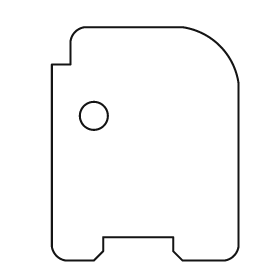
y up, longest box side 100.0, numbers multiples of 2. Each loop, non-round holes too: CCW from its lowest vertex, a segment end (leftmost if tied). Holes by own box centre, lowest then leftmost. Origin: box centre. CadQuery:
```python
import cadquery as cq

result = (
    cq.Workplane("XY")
    .moveTo(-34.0, -50.0)
    .lineTo(-22.0, -50.0)
    .lineTo(-18.0, -46.0)
    .lineTo(-18.0, -40.0)
    .lineTo(12.0, -40.0)
    .lineTo(12.0, -46.0)
    .lineTo(16.0, -50.0)
    .lineTo(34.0, -50.0)
    .threePointArc((38.0, -48.0), (40.0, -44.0))
    .lineTo(40.0, 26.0)
    .threePointArc((32.0, 42.0), (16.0, 50.0))
    .lineTo(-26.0, 50.0)
    .threePointArc((-30.0, 48.0), (-32.0, 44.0))
    .lineTo(-32.0, 34.0)
    .lineTo(-40.0, 34.0)
    .lineTo(-40.0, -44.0)
    .threePointArc((-38.0, -48.0), (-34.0, -50.0))
    .close()
    .moveTo(-22.0, 12.0)
    .circle(6.0)
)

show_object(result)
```